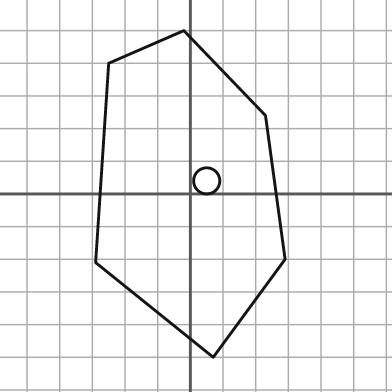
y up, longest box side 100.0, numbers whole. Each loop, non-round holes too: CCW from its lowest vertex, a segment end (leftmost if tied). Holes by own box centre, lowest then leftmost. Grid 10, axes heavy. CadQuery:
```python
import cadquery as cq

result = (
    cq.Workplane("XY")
    .moveTo(7.0, -50.0)
    .lineTo(29.0, -20.0)
    .lineTo(23.0, 24.0)
    .lineTo(-2.0, 50.0)
    .lineTo(-25.0, 40.0)
    .lineTo(-29.0, -21.0)
    .close()
    .moveTo(5.0, 4.0)
    .circle(4.0)
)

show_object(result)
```